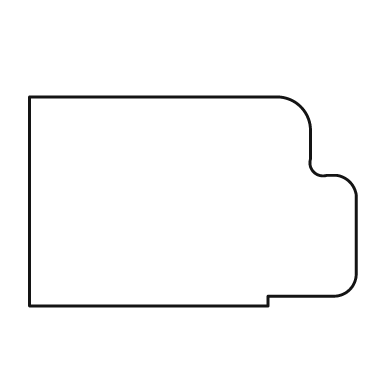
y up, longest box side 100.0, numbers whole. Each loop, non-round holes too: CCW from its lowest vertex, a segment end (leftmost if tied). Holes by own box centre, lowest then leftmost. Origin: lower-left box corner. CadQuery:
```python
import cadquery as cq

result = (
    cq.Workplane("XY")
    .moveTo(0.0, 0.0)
    .lineTo(73.0, 0.0)
    .lineTo(73.0, 3.0)
    .lineTo(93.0, 3.0)
    .threePointArc((98.0, 5.0), (100.0, 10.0))
    .lineTo(100.0, 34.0)
    .threePointArc((98.0, 38.0), (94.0, 40.0))
    .lineTo(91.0, 40.0)
    .threePointArc((87.0, 41.0), (86.0, 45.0))
    .lineTo(86.0, 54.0)
    .threePointArc((83.0, 61.0), (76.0, 64.0))
    .lineTo(0.0, 64.0)
    .close()
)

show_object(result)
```